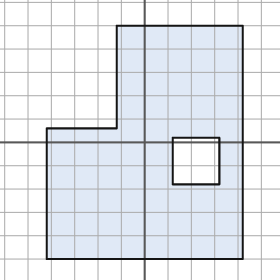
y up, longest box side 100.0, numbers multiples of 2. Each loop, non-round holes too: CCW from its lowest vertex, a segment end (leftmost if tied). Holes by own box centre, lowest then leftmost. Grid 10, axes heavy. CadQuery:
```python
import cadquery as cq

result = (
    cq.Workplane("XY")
    .moveTo(-42.0, -50.0)
    .lineTo(42.0, -50.0)
    .lineTo(42.0, 50.0)
    .lineTo(-12.0, 50.0)
    .lineTo(-12.0, 6.0)
    .lineTo(-42.0, 6.0)
    .close()
    .moveTo(12.0, -18.0)
    .lineTo(32.0, -18.0)
    .lineTo(32.0, 2.0)
    .lineTo(12.0, 2.0)
    .close()
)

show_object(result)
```